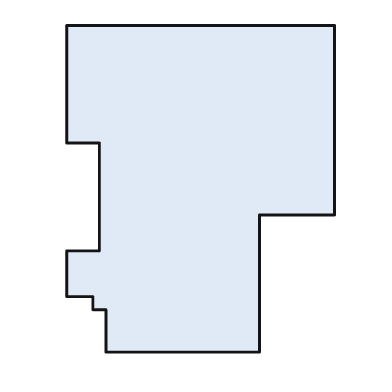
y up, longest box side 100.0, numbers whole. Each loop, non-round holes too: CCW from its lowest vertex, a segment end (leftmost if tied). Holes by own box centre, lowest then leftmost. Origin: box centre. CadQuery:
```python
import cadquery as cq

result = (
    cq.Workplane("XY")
    .moveTo(-29.0, -50.0)
    .lineTo(18.0, -50.0)
    .lineTo(18.0, -8.0)
    .lineTo(41.0, -8.0)
    .lineTo(41.0, 50.0)
    .lineTo(-41.0, 50.0)
    .lineTo(-41.0, 14.0)
    .lineTo(-31.0, 14.0)
    .lineTo(-31.0, -19.0)
    .lineTo(-41.0, -19.0)
    .lineTo(-41.0, -33.0)
    .lineTo(-33.0, -33.0)
    .lineTo(-33.0, -37.0)
    .lineTo(-29.0, -37.0)
    .close()
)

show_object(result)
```